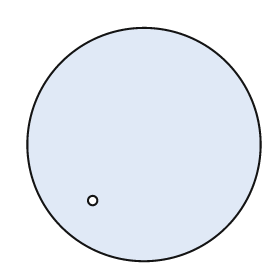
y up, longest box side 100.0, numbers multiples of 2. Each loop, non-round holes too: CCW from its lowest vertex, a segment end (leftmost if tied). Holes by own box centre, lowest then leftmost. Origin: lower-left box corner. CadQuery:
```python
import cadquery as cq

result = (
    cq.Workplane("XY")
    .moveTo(50.0, 50.0)
    .circle(50.0)
    .moveTo(28.0, 26.0)
    .circle(2.0)
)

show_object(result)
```